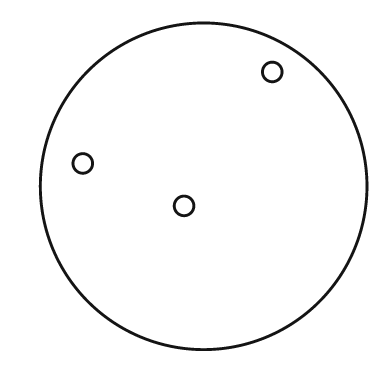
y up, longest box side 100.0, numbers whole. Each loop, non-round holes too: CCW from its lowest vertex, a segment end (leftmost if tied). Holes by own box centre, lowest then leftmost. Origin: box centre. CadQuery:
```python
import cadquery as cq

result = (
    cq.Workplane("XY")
    .moveTo(0.0, 0.0)
    .circle(50.0)
    .moveTo(-6.0, -6.0)
    .circle(3.0)
    .moveTo(-37.0, 7.0)
    .circle(3.0)
    .moveTo(21.0, 35.0)
    .circle(3.0)
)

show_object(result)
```